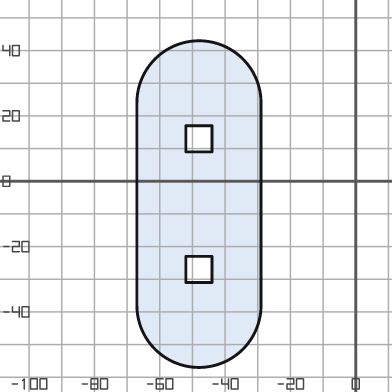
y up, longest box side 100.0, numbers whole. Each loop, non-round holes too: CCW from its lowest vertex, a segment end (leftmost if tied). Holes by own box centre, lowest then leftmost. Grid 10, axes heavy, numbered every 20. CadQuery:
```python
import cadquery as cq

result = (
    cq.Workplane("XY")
    .moveTo(-67.0, -38.0)
    .threePointArc((-48.0, -57.0), (-29.0, -38.0))
    .lineTo(-29.0, 24.0)
    .threePointArc((-48.0, 43.0), (-67.0, 24.0))
    .close()
    .moveTo(-52.0, -31.0)
    .lineTo(-44.0, -31.0)
    .lineTo(-44.0, -23.0)
    .lineTo(-52.0, -23.0)
    .close()
    .moveTo(-52.0, 9.0)
    .lineTo(-44.0, 9.0)
    .lineTo(-44.0, 17.0)
    .lineTo(-52.0, 17.0)
    .close()
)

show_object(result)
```